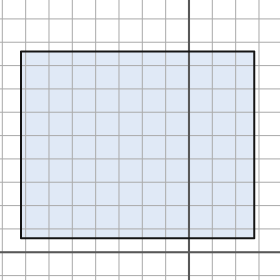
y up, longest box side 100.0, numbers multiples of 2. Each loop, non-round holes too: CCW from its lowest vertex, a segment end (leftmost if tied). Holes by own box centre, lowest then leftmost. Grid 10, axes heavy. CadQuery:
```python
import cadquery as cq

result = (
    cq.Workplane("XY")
    .moveTo(-72.0, 6.0)
    .lineTo(28.0, 6.0)
    .lineTo(28.0, 86.0)
    .lineTo(-72.0, 86.0)
    .close()
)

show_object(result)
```